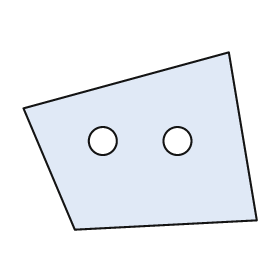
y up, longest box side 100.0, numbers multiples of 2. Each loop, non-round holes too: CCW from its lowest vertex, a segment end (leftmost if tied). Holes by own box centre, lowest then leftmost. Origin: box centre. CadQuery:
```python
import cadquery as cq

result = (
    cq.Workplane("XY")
    .moveTo(-28.0, -38.0)
    .lineTo(50.0, -34.0)
    .lineTo(38.0, 38.0)
    .lineTo(-50.0, 14.0)
    .close()
    .moveTo(-16.0, 0.0)
    .circle(6.0)
    .moveTo(16.0, 0.0)
    .circle(6.0)
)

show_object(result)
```